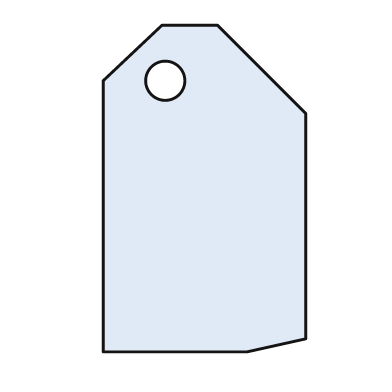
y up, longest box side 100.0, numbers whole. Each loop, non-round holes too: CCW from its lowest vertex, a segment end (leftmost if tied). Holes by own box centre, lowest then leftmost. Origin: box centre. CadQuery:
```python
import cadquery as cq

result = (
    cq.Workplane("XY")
    .moveTo(-31.0, -50.0)
    .lineTo(13.0, -50.0)
    .lineTo(31.0, -46.0)
    .lineTo(31.0, 23.0)
    .lineTo(4.0, 50.0)
    .lineTo(-13.0, 50.0)
    .lineTo(-31.0, 33.0)
    .close()
    .moveTo(-12.0, 33.0)
    .circle(6.0)
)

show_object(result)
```